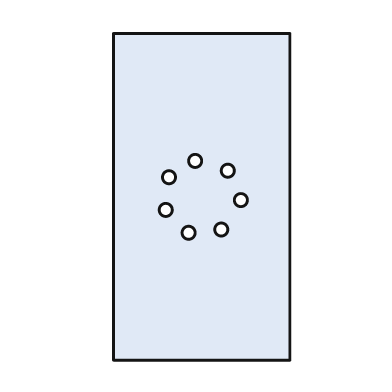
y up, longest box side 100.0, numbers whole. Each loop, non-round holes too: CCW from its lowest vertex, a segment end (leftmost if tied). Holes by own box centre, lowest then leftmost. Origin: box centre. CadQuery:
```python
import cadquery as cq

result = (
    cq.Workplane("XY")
    .moveTo(-27.0, -50.0)
    .lineTo(27.0, -50.0)
    .lineTo(27.0, 50.0)
    .lineTo(-27.0, 50.0)
    .close()
    .moveTo(-4.0, -11.0)
    .circle(2.0)
    .moveTo(6.0, -10.0)
    .circle(2.0)
    .moveTo(-11.0, -4.0)
    .circle(2.0)
    .moveTo(12.0, -1.0)
    .circle(2.0)
    .moveTo(-10.0, 6.0)
    .circle(2.0)
    .moveTo(8.0, 8.0)
    .circle(2.0)
    .moveTo(-2.0, 11.0)
    .circle(2.0)
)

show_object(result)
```